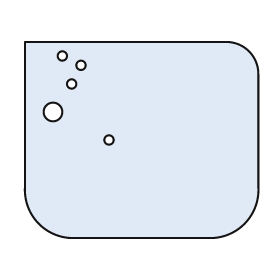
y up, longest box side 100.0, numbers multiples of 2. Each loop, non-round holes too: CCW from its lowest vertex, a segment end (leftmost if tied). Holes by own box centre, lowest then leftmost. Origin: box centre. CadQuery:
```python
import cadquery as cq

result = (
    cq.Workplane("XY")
    .moveTo(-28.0, -42.0)
    .lineTo(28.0, -42.0)
    .threePointArc((44.0, -36.0), (50.0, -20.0))
    .lineTo(50.0, 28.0)
    .threePointArc((46.0, 38.0), (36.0, 42.0))
    .lineTo(-50.0, 42.0)
    .lineTo(-50.0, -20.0)
    .threePointArc((-44.0, -36.0), (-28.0, -42.0))
    .close()
    .moveTo(-14.0, 0.0)
    .circle(2.0)
    .moveTo(-38.0, 12.0)
    .circle(4.0)
    .moveTo(-30.0, 24.0)
    .circle(2.0)
    .moveTo(-26.0, 32.0)
    .circle(2.0)
    .moveTo(-34.0, 36.0)
    .circle(2.0)
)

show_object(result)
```